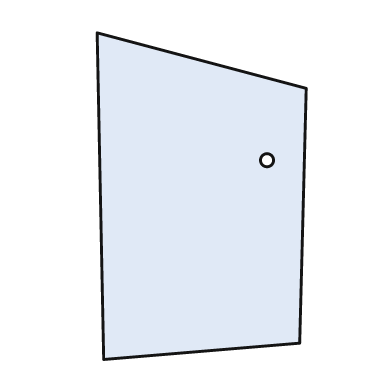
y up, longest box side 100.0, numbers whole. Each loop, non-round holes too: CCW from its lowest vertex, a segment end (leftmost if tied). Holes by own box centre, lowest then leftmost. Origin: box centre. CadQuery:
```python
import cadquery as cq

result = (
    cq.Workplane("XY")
    .moveTo(-30.0, -50.0)
    .lineTo(30.0, -45.0)
    .lineTo(32.0, 33.0)
    .lineTo(-32.0, 50.0)
    .close()
    .moveTo(20.0, 11.0)
    .circle(2.0)
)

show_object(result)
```